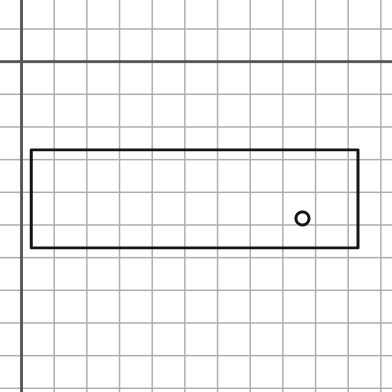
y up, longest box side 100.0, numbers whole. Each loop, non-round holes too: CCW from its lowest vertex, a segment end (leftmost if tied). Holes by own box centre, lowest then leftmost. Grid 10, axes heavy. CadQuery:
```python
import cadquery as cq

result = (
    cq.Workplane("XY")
    .moveTo(3.0, -57.0)
    .lineTo(103.0, -57.0)
    .lineTo(103.0, -27.0)
    .lineTo(3.0, -27.0)
    .close()
    .moveTo(86.0, -48.0)
    .circle(2.0)
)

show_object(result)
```